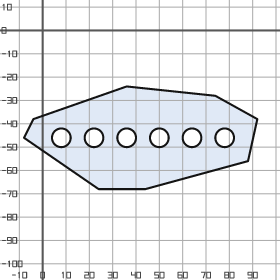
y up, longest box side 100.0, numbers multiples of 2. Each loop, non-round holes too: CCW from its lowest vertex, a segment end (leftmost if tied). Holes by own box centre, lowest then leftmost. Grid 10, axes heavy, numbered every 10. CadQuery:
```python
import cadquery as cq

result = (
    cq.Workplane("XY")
    .moveTo(24.0, -68.0)
    .lineTo(44.0, -68.0)
    .lineTo(88.0, -56.0)
    .lineTo(92.0, -38.0)
    .lineTo(74.0, -28.0)
    .lineTo(36.0, -24.0)
    .lineTo(-4.0, -38.0)
    .lineTo(-8.0, -46.0)
    .close()
    .moveTo(8.0, -46.0)
    .circle(4.0)
    .moveTo(22.0, -46.0)
    .circle(4.0)
    .moveTo(36.0, -46.0)
    .circle(4.0)
    .moveTo(50.0, -46.0)
    .circle(4.0)
    .moveTo(64.0, -46.0)
    .circle(4.0)
    .moveTo(78.0, -46.0)
    .circle(4.0)
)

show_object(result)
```